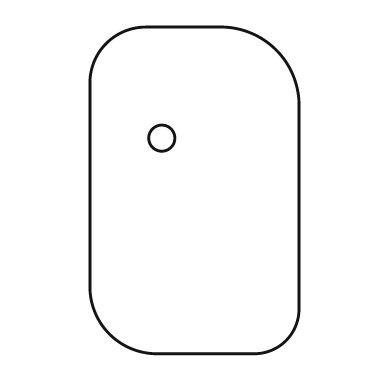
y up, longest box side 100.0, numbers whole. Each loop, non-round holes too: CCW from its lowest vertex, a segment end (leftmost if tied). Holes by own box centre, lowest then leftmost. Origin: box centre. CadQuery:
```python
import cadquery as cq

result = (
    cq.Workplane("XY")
    .moveTo(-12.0, -50.0)
    .lineTo(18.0, -50.0)
    .threePointArc((28.0, -46.0), (32.0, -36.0))
    .lineTo(32.0, 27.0)
    .threePointArc((25.0, 43.0), (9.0, 50.0))
    .lineTo(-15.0, 50.0)
    .threePointArc((-27.0, 45.0), (-32.0, 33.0))
    .lineTo(-32.0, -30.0)
    .threePointArc((-26.0, -44.0), (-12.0, -50.0))
    .close()
    .moveTo(-10.0, 16.0)
    .circle(4.0)
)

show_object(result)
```